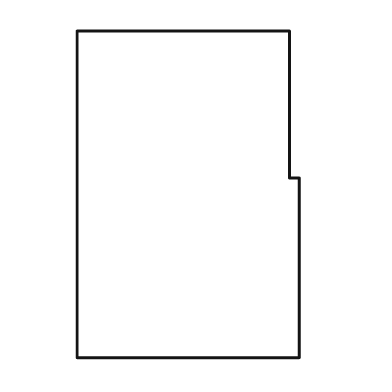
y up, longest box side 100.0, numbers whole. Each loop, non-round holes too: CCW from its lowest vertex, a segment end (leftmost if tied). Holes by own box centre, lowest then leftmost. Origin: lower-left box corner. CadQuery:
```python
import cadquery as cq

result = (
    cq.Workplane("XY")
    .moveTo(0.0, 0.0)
    .lineTo(68.0, 0.0)
    .lineTo(68.0, 55.0)
    .lineTo(65.0, 55.0)
    .lineTo(65.0, 100.0)
    .lineTo(0.0, 100.0)
    .close()
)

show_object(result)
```